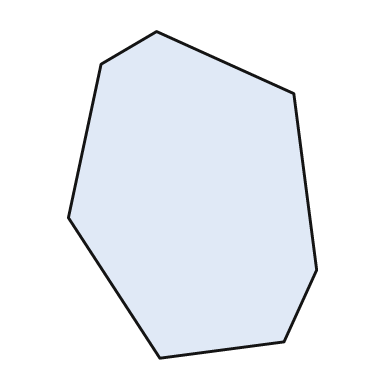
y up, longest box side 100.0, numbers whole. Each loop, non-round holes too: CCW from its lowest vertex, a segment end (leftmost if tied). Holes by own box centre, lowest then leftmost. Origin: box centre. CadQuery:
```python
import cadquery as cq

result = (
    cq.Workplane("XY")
    .moveTo(-10.0, -50.0)
    .lineTo(28.0, -45.0)
    .lineTo(38.0, -23.0)
    .lineTo(31.0, 31.0)
    .lineTo(-11.0, 50.0)
    .lineTo(-28.0, 40.0)
    .lineTo(-38.0, -7.0)
    .close()
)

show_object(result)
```